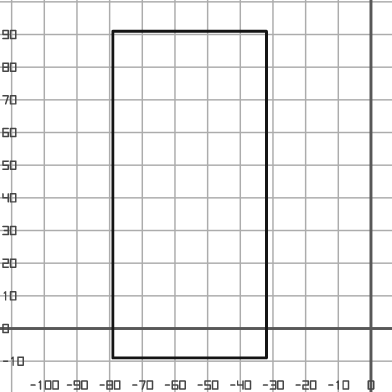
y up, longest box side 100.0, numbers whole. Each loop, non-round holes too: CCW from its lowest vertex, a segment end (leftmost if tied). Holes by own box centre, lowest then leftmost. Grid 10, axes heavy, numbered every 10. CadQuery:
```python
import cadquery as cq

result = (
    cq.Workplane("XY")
    .moveTo(-79.0, -9.0)
    .lineTo(-32.0, -9.0)
    .lineTo(-32.0, 91.0)
    .lineTo(-79.0, 91.0)
    .close()
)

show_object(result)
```